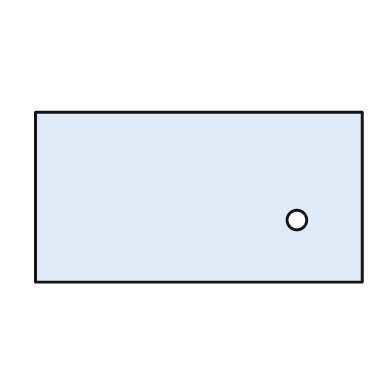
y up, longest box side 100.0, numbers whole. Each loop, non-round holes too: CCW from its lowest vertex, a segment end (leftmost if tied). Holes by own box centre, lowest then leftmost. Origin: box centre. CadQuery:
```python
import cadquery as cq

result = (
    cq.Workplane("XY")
    .moveTo(-50.0, -26.0)
    .lineTo(50.0, -26.0)
    .lineTo(50.0, 26.0)
    .lineTo(-50.0, 26.0)
    .close()
    .moveTo(30.0, -7.0)
    .circle(3.0)
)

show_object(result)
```